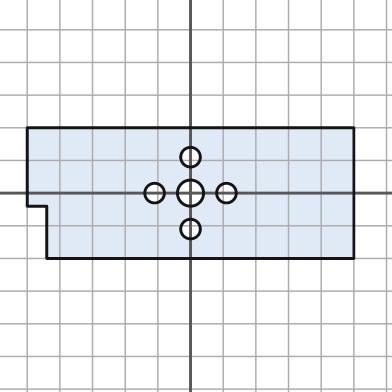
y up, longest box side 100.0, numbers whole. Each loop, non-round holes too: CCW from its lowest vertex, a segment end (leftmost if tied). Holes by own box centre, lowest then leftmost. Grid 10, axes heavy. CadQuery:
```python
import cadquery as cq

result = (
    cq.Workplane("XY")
    .moveTo(-44.0, -20.0)
    .lineTo(50.0, -20.0)
    .lineTo(50.0, 20.0)
    .lineTo(-50.0, 20.0)
    .lineTo(-50.0, -4.0)
    .lineTo(-44.0, -4.0)
    .close()
    .moveTo(0.0, -11.0)
    .circle(3.0)
    .moveTo(-11.0, 0.0)
    .circle(3.0)
    .moveTo(0.0, 0.0)
    .circle(4.0)
    .moveTo(11.0, 0.0)
    .circle(3.0)
    .moveTo(0.0, 11.0)
    .circle(3.0)
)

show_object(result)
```